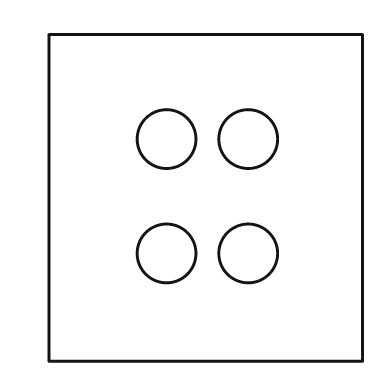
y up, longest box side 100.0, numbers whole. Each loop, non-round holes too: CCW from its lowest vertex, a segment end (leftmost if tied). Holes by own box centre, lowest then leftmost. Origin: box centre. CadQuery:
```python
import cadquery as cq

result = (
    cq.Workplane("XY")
    .moveTo(-48.0, -50.0)
    .lineTo(48.0, -50.0)
    .lineTo(48.0, 50.0)
    .lineTo(-48.0, 50.0)
    .close()
    .moveTo(-12.0, -17.0)
    .circle(9.0)
    .moveTo(13.0, -17.0)
    .circle(9.0)
    .moveTo(-12.0, 18.0)
    .circle(9.0)
    .moveTo(13.0, 18.0)
    .circle(9.0)
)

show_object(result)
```